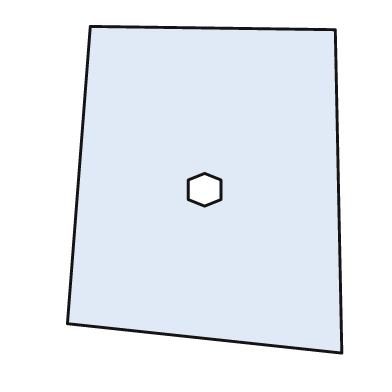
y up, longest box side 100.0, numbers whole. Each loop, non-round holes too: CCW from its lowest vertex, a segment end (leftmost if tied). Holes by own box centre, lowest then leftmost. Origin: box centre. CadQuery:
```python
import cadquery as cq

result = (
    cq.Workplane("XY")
    .moveTo(42.0, -50.0)
    .lineTo(40.0, 49.0)
    .lineTo(-35.0, 50.0)
    .lineTo(-42.0, -41.0)
    .close()
    .moveTo(0.0, -5.0)
    .lineTo(5.0, -3.0)
    .lineTo(5.0, 3.0)
    .lineTo(0.0, 5.0)
    .lineTo(-5.0, 3.0)
    .lineTo(-5.0, -3.0)
    .close()
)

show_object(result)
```